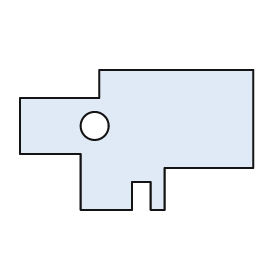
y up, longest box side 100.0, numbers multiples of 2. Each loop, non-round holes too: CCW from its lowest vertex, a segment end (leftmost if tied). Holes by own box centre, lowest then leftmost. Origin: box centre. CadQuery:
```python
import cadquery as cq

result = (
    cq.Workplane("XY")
    .moveTo(-24.0, -30.0)
    .lineTo(-2.0, -30.0)
    .lineTo(-2.0, -18.0)
    .lineTo(6.0, -18.0)
    .lineTo(6.0, -30.0)
    .lineTo(12.0, -30.0)
    .lineTo(12.0, -12.0)
    .lineTo(50.0, -12.0)
    .lineTo(50.0, 30.0)
    .lineTo(-16.0, 30.0)
    .lineTo(-16.0, 18.0)
    .lineTo(-50.0, 18.0)
    .lineTo(-50.0, -6.0)
    .lineTo(-24.0, -6.0)
    .close()
    .moveTo(-18.0, 6.0)
    .circle(6.0)
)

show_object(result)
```